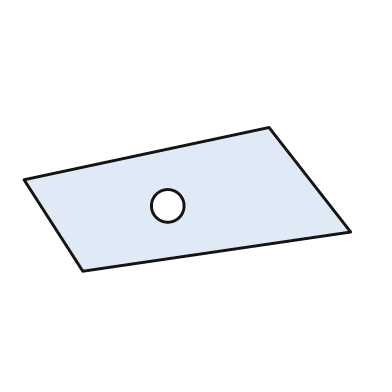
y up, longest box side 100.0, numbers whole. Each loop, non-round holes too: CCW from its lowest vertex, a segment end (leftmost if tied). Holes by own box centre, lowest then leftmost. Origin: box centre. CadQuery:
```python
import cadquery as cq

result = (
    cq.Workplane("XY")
    .moveTo(-32.0, -22.0)
    .lineTo(50.0, -10.0)
    .lineTo(25.0, 22.0)
    .lineTo(-50.0, 6.0)
    .close()
    .moveTo(-6.0, -2.0)
    .circle(5.0)
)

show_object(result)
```